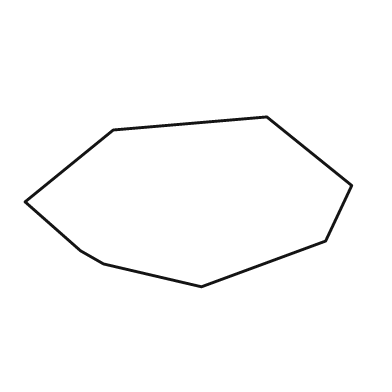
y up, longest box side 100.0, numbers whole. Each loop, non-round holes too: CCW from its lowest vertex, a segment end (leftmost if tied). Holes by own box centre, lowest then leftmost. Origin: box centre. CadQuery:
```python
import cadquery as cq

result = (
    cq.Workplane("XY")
    .moveTo(4.0, -26.0)
    .lineTo(42.0, -12.0)
    .lineTo(50.0, 5.0)
    .lineTo(24.0, 26.0)
    .lineTo(-23.0, 22.0)
    .lineTo(-50.0, 0.0)
    .lineTo(-33.0, -15.0)
    .lineTo(-26.0, -19.0)
    .close()
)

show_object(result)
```